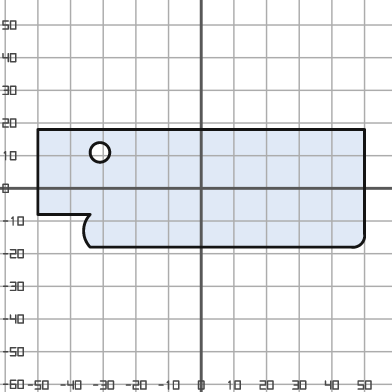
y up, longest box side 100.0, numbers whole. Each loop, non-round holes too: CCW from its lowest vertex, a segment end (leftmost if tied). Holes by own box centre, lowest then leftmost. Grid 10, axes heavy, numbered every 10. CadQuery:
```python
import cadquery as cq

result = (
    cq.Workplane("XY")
    .moveTo(-34.0, -18.0)
    .lineTo(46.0, -18.0)
    .threePointArc((49.0, -17.0), (50.0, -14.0))
    .lineTo(50.0, 18.0)
    .lineTo(-50.0, 18.0)
    .lineTo(-50.0, -8.0)
    .lineTo(-34.0, -8.0)
    .threePointArc((-36.0, -13.0), (-34.0, -18.0))
    .close()
    .moveTo(-31.0, 11.0)
    .circle(3.0)
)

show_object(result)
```